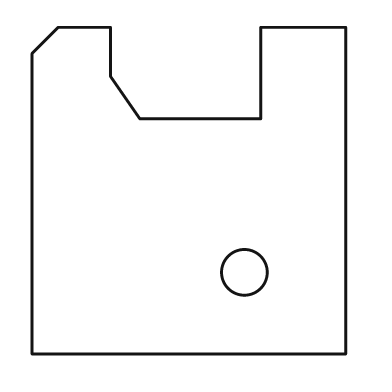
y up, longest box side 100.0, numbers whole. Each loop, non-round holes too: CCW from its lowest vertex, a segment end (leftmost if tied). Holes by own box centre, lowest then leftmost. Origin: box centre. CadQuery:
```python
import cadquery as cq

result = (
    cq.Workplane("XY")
    .moveTo(-48.0, -50.0)
    .lineTo(48.0, -50.0)
    .lineTo(48.0, 50.0)
    .lineTo(22.0, 50.0)
    .lineTo(22.0, 22.0)
    .lineTo(-15.0, 22.0)
    .lineTo(-24.0, 35.0)
    .lineTo(-24.0, 50.0)
    .lineTo(-40.0, 50.0)
    .lineTo(-48.0, 42.0)
    .close()
    .moveTo(17.0, -25.0)
    .circle(7.0)
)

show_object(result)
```